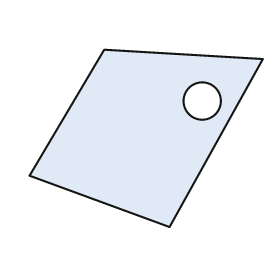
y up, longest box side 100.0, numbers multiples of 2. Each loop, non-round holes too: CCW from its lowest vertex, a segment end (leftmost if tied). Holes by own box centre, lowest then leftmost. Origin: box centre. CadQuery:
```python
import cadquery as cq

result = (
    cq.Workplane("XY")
    .moveTo(10.0, -38.0)
    .lineTo(50.0, 34.0)
    .lineTo(-18.0, 38.0)
    .lineTo(-50.0, -16.0)
    .close()
    .moveTo(24.0, 16.0)
    .circle(8.0)
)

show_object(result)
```